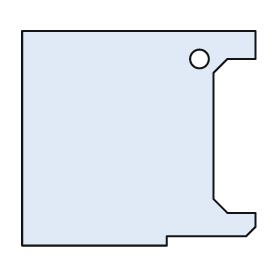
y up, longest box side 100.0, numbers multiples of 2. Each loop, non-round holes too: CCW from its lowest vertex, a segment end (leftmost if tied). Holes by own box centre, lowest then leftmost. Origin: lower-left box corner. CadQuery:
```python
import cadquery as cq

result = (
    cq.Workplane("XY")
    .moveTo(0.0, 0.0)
    .lineTo(62.0, 0.0)
    .lineTo(62.0, 4.0)
    .lineTo(96.0, 4.0)
    .lineTo(100.0, 8.0)
    .lineTo(100.0, 14.0)
    .lineTo(88.0, 14.0)
    .lineTo(82.0, 20.0)
    .lineTo(82.0, 74.0)
    .lineTo(88.0, 80.0)
    .lineTo(100.0, 80.0)
    .lineTo(100.0, 92.0)
    .lineTo(0.0, 92.0)
    .close()
    .moveTo(76.0, 80.0)
    .circle(4.0)
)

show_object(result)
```